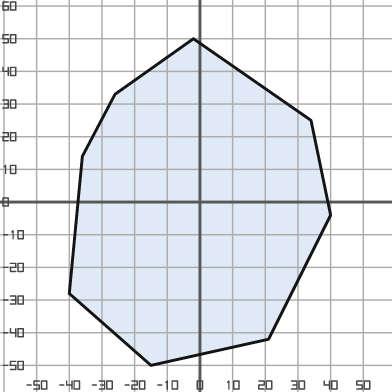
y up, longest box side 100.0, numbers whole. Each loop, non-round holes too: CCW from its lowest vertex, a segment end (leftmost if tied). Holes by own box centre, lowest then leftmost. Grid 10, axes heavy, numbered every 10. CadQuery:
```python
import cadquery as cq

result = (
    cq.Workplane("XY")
    .moveTo(-15.0, -50.0)
    .lineTo(21.0, -42.0)
    .lineTo(40.0, -4.0)
    .lineTo(34.0, 25.0)
    .lineTo(-2.0, 50.0)
    .lineTo(-26.0, 33.0)
    .lineTo(-36.0, 14.0)
    .lineTo(-40.0, -28.0)
    .close()
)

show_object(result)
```